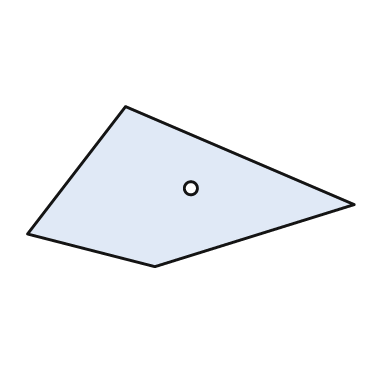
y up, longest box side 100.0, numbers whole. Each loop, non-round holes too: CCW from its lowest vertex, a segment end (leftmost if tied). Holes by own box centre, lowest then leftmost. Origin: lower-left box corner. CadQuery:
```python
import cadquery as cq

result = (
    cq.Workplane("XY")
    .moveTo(39.0, 0.0)
    .lineTo(100.0, 19.0)
    .lineTo(30.0, 49.0)
    .lineTo(0.0, 10.0)
    .close()
    .moveTo(50.0, 24.0)
    .circle(2.0)
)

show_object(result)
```